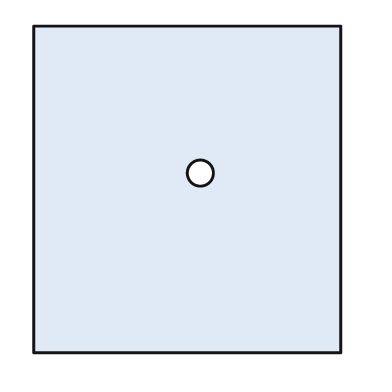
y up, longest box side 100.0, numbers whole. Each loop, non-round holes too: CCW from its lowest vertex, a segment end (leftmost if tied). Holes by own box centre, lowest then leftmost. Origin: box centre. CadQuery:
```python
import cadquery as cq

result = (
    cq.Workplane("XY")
    .moveTo(-47.0, -50.0)
    .lineTo(47.0, -50.0)
    .lineTo(47.0, 50.0)
    .lineTo(-47.0, 50.0)
    .close()
    .moveTo(4.0, 5.0)
    .circle(4.0)
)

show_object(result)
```